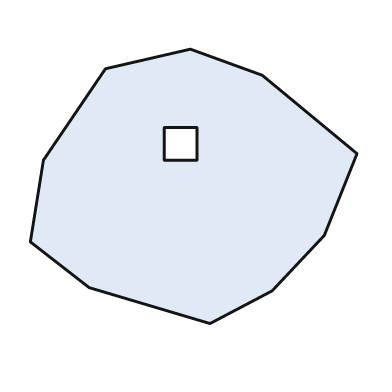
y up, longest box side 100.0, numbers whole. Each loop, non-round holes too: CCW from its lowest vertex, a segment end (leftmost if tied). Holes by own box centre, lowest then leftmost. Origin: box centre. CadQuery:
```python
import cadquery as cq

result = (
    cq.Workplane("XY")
    .moveTo(5.0, -42.0)
    .lineTo(24.0, -32.0)
    .lineTo(40.0, -15.0)
    .lineTo(50.0, 10.0)
    .lineTo(21.0, 34.0)
    .lineTo(-1.0, 42.0)
    .lineTo(-27.0, 36.0)
    .lineTo(-46.0, 8.0)
    .lineTo(-50.0, -17.0)
    .lineTo(-32.0, -31.0)
    .close()
    .moveTo(-9.0, 8.0)
    .lineTo(1.0, 8.0)
    .lineTo(1.0, 18.0)
    .lineTo(-9.0, 18.0)
    .close()
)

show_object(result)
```